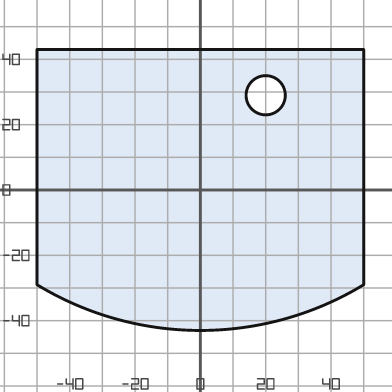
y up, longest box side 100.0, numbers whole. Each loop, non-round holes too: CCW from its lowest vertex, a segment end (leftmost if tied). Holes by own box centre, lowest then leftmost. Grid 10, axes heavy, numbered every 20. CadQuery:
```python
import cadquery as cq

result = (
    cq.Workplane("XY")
    .moveTo(-50.0, -29.0)
    .threePointArc((0.0, -43.0), (50.0, -29.0))
    .lineTo(50.0, 43.0)
    .lineTo(-50.0, 43.0)
    .close()
    .moveTo(20.0, 29.0)
    .circle(6.0)
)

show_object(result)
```